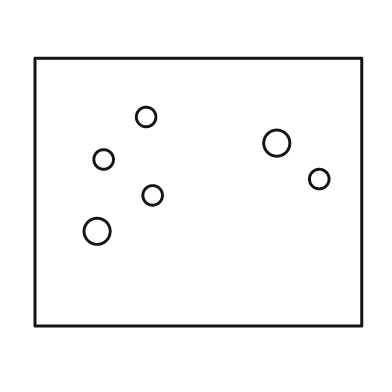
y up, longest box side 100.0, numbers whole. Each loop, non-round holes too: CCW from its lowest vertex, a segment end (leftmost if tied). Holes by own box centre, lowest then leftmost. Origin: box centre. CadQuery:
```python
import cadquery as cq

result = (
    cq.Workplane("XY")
    .moveTo(-50.0, -41.0)
    .lineTo(50.0, -41.0)
    .lineTo(50.0, 41.0)
    .lineTo(-50.0, 41.0)
    .close()
    .moveTo(-31.0, -12.0)
    .circle(4.0)
    .moveTo(-14.0, -1.0)
    .circle(3.0)
    .moveTo(37.0, 4.0)
    .circle(3.0)
    .moveTo(-29.0, 10.0)
    .circle(3.0)
    .moveTo(24.0, 15.0)
    .circle(4.0)
    .moveTo(-16.0, 23.0)
    .circle(3.0)
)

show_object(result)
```